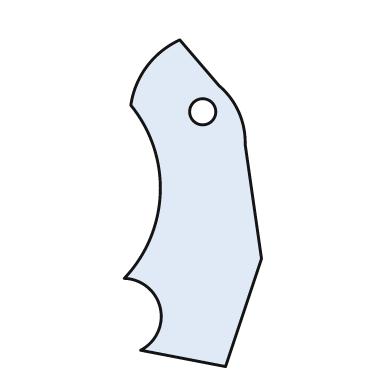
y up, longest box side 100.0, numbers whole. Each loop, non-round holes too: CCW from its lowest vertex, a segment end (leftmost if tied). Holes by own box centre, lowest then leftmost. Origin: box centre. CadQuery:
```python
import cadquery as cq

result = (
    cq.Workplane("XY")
    .moveTo(10.0, -50.0)
    .lineTo(21.0, -17.0)
    .lineTo(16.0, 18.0)
    .threePointArc((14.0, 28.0), (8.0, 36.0))
    .lineTo(-4.0, 50.0)
    .threePointArc((-14.0, 42.0), (-19.0, 30.0))
    .threePointArc((-10.0, 3.0), (-21.0, -23.0))
    .threePointArc((-10.0, -32.0), (-16.0, -45.0))
    .close()
    .moveTo(3.0, 28.0)
    .circle(4.0)
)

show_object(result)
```